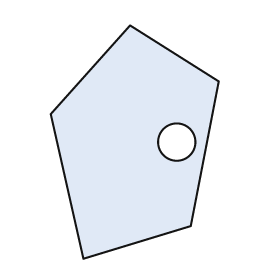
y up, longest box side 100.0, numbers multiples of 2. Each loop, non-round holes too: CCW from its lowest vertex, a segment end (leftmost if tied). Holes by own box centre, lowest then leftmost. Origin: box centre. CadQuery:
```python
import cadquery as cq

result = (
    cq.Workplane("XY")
    .moveTo(-22.0, -50.0)
    .lineTo(24.0, -36.0)
    .lineTo(36.0, 26.0)
    .lineTo(-2.0, 50.0)
    .lineTo(-36.0, 12.0)
    .close()
    .moveTo(18.0, 0.0)
    .circle(8.0)
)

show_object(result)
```